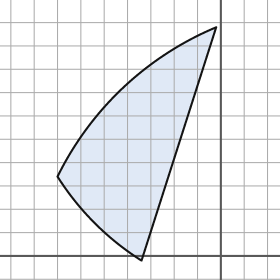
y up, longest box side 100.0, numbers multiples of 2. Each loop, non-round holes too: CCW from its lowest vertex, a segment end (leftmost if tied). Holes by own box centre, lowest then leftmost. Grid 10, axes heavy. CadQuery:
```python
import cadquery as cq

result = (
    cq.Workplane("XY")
    .moveTo(-34.0, -2.0)
    .lineTo(-2.0, 98.0)
    .threePointArc((-42.0, 72.0), (-70.0, 34.0))
    .threePointArc((-54.0, 14.0), (-34.0, -2.0))
    .close()
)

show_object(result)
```